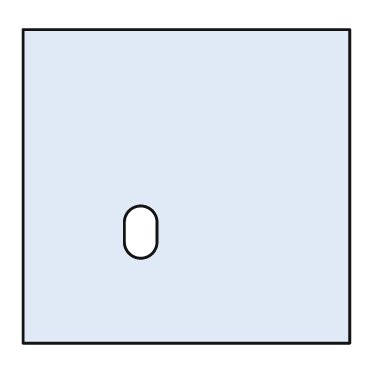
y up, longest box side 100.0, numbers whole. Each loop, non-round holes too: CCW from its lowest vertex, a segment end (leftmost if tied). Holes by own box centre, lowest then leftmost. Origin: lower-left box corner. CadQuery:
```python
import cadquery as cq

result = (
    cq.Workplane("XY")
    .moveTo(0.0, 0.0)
    .lineTo(100.0, 0.0)
    .lineTo(100.0, 96.0)
    .lineTo(0.0, 96.0)
    .close()
    .moveTo(31.0, 31.0)
    .threePointArc((36.0, 26.0), (41.0, 31.0))
    .lineTo(41.0, 37.0)
    .threePointArc((36.0, 42.0), (31.0, 37.0))
    .close()
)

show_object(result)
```